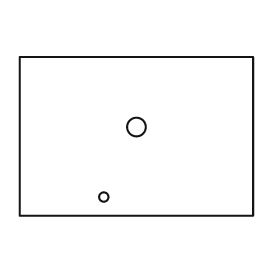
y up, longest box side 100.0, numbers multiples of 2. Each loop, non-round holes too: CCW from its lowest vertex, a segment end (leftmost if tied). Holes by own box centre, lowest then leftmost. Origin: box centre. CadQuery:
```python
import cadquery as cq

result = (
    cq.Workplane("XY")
    .moveTo(-50.0, -34.0)
    .lineTo(50.0, -34.0)
    .lineTo(50.0, 34.0)
    .lineTo(-50.0, 34.0)
    .close()
    .moveTo(-14.0, -26.0)
    .circle(2.0)
    .moveTo(0.0, 4.0)
    .circle(4.0)
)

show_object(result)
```